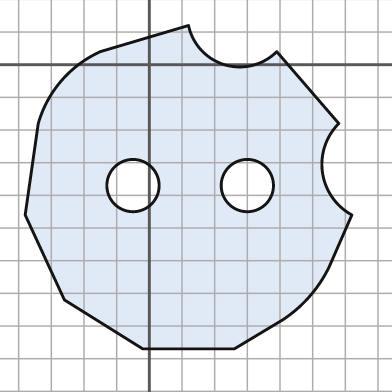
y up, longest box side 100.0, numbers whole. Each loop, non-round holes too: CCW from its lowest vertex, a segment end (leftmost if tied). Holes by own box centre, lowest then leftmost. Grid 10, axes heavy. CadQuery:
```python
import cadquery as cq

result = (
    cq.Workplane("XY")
    .moveTo(-2.0, -87.0)
    .lineTo(26.0, -87.0)
    .lineTo(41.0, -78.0)
    .threePointArc((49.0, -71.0), (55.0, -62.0))
    .lineTo(62.0, -46.0)
    .threePointArc((53.0, -33.0), (58.0, -18.0))
    .lineTo(39.0, 4.0)
    .threePointArc((23.0, 0.0), (12.0, 12.0))
    .lineTo(-15.0, 4.0)
    .threePointArc((-27.0, -5.0), (-34.0, -18.0))
    .lineTo(-38.0, -46.0)
    .lineTo(-26.0, -72.0)
    .close()
    .moveTo(-5.0, -37.0)
    .circle(8.0)
    .moveTo(30.0, -37.0)
    .circle(8.0)
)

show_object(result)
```